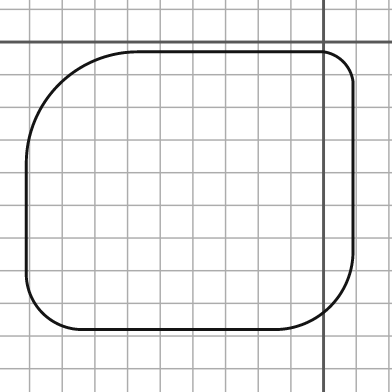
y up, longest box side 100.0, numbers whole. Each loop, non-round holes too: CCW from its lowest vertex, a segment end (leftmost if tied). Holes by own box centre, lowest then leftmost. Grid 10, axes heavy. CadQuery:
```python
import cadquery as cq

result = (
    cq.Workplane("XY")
    .moveTo(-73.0, -88.0)
    .lineTo(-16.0, -88.0)
    .threePointArc((2.0, -81.0), (9.0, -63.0))
    .lineTo(9.0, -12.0)
    .threePointArc((6.0, -6.0), (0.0, -3.0))
    .lineTo(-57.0, -3.0)
    .threePointArc((-81.0, -13.0), (-91.0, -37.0))
    .lineTo(-91.0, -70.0)
    .threePointArc((-86.0, -83.0), (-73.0, -88.0))
    .close()
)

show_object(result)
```